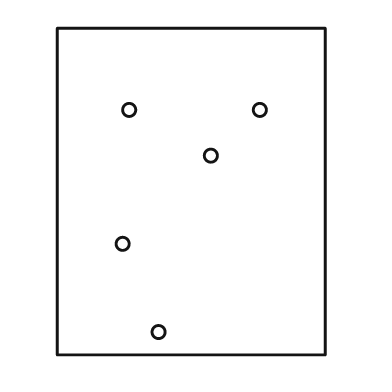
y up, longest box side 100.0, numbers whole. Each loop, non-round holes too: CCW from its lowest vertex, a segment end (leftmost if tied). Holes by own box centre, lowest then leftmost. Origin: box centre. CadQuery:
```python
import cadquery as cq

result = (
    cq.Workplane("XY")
    .moveTo(-41.0, -50.0)
    .lineTo(41.0, -50.0)
    .lineTo(41.0, 50.0)
    .lineTo(-41.0, 50.0)
    .close()
    .moveTo(-10.0, -43.0)
    .circle(2.0)
    .moveTo(-21.0, -16.0)
    .circle(2.0)
    .moveTo(6.0, 11.0)
    .circle(2.0)
    .moveTo(-19.0, 25.0)
    .circle(2.0)
    .moveTo(21.0, 25.0)
    .circle(2.0)
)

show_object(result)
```